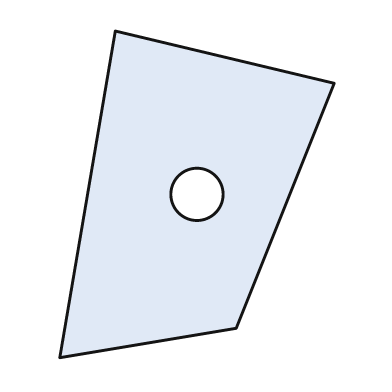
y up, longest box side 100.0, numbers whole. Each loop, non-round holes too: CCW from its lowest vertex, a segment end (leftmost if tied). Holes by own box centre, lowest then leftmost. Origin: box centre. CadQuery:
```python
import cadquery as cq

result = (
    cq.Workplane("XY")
    .moveTo(-42.0, -50.0)
    .lineTo(12.0, -41.0)
    .lineTo(42.0, 34.0)
    .lineTo(-25.0, 50.0)
    .close()
    .moveTo(0.0, 0.0)
    .circle(8.0)
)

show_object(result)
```